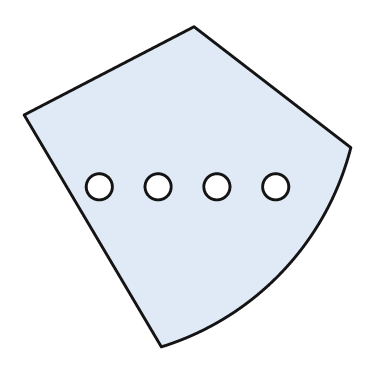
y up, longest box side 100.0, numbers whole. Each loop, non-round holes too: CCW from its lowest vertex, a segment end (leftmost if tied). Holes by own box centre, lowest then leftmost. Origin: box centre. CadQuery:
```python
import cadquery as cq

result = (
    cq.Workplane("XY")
    .moveTo(-8.0, -49.0)
    .threePointArc((29.0, -26.0), (50.0, 12.0))
    .lineTo(2.0, 49.0)
    .lineTo(-50.0, 22.0)
    .close()
    .moveTo(-27.0, 0.0)
    .circle(4.0)
    .moveTo(-9.0, 0.0)
    .circle(4.0)
    .moveTo(9.0, 0.0)
    .circle(4.0)
    .moveTo(27.0, 0.0)
    .circle(4.0)
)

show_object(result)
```